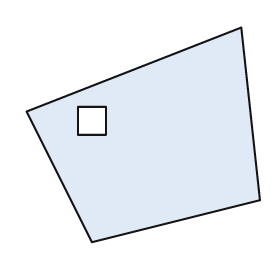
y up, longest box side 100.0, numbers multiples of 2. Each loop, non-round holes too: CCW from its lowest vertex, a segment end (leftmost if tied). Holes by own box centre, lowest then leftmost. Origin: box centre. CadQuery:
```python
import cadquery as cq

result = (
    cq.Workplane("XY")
    .moveTo(-22.0, -46.0)
    .lineTo(50.0, -28.0)
    .lineTo(42.0, 46.0)
    .lineTo(-50.0, 10.0)
    .close()
    .moveTo(-28.0, 0.0)
    .lineTo(-16.0, 0.0)
    .lineTo(-16.0, 12.0)
    .lineTo(-28.0, 12.0)
    .close()
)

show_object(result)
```